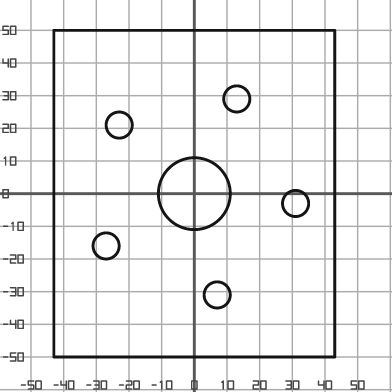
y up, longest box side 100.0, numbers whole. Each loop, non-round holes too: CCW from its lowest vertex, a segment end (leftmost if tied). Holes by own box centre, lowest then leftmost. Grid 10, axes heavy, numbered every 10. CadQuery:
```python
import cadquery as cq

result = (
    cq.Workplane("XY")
    .moveTo(-43.0, -50.0)
    .lineTo(43.0, -50.0)
    .lineTo(43.0, 50.0)
    .lineTo(-43.0, 50.0)
    .close()
    .moveTo(7.0, -31.0)
    .circle(4.0)
    .moveTo(-27.0, -16.0)
    .circle(4.0)
    .moveTo(31.0, -3.0)
    .circle(4.0)
    .moveTo(0.0, 0.0)
    .circle(11.0)
    .moveTo(-23.0, 21.0)
    .circle(4.0)
    .moveTo(13.0, 29.0)
    .circle(4.0)
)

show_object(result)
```